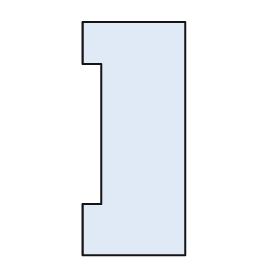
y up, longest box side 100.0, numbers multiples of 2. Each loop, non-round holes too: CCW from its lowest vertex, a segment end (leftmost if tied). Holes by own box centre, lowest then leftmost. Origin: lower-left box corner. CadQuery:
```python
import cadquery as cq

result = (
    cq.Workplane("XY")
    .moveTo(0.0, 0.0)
    .lineTo(44.0, 0.0)
    .lineTo(44.0, 100.0)
    .lineTo(0.0, 100.0)
    .lineTo(0.0, 82.0)
    .lineTo(8.0, 82.0)
    .lineTo(8.0, 22.0)
    .lineTo(0.0, 22.0)
    .close()
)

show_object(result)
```